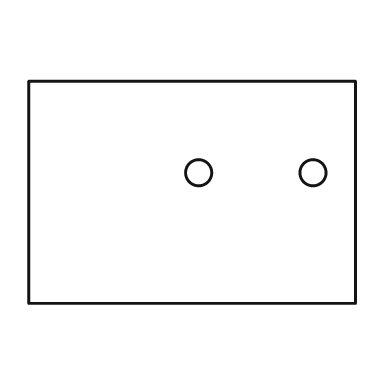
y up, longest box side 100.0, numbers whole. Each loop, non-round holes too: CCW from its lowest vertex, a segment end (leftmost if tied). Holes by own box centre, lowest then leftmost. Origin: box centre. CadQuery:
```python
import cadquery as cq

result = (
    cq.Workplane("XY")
    .moveTo(-50.0, -34.0)
    .lineTo(50.0, -34.0)
    .lineTo(50.0, 34.0)
    .lineTo(-50.0, 34.0)
    .close()
    .moveTo(2.0, 6.0)
    .circle(4.0)
    .moveTo(37.0, 6.0)
    .circle(4.0)
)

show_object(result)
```